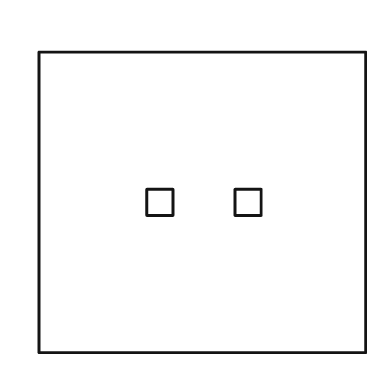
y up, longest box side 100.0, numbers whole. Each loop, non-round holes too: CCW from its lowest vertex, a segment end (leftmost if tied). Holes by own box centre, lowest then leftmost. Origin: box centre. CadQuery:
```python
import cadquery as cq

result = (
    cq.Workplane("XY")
    .moveTo(-50.0, -46.0)
    .lineTo(50.0, -46.0)
    .lineTo(50.0, 46.0)
    .lineTo(-50.0, 46.0)
    .close()
    .moveTo(-17.0, -4.0)
    .lineTo(-9.0, -4.0)
    .lineTo(-9.0, 4.0)
    .lineTo(-17.0, 4.0)
    .close()
    .moveTo(10.0, -4.0)
    .lineTo(18.0, -4.0)
    .lineTo(18.0, 4.0)
    .lineTo(10.0, 4.0)
    .close()
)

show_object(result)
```